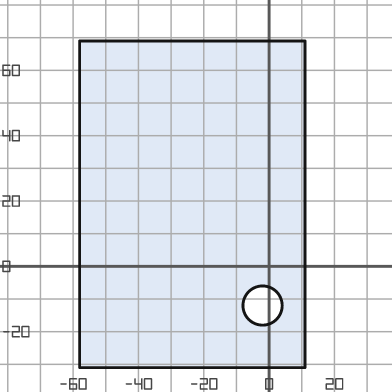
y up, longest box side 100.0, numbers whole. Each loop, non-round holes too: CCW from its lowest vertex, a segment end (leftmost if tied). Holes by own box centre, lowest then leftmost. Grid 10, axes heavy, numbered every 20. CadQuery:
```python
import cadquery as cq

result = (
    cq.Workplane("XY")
    .moveTo(-58.0, -31.0)
    .lineTo(11.0, -31.0)
    .lineTo(11.0, 69.0)
    .lineTo(-58.0, 69.0)
    .close()
    .moveTo(-2.0, -12.0)
    .circle(6.0)
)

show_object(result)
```